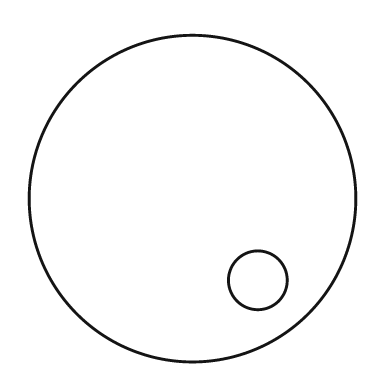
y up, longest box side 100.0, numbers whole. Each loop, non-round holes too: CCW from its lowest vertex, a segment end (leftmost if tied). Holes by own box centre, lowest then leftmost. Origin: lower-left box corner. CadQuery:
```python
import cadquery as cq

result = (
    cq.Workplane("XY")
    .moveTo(50.0, 50.0)
    .circle(50.0)
    .moveTo(70.0, 25.0)
    .circle(9.0)
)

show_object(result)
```